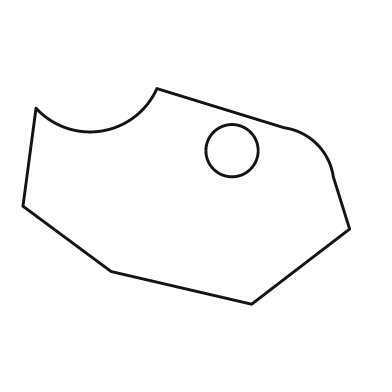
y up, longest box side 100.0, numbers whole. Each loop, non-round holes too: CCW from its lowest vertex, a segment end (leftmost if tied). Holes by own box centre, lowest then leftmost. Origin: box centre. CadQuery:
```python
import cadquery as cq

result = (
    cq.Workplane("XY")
    .moveTo(20.0, -33.0)
    .lineTo(50.0, -10.0)
    .lineTo(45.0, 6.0)
    .threePointArc((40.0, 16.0), (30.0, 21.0))
    .lineTo(-9.0, 33.0)
    .threePointArc((-26.0, 20.0), (-46.0, 27.0))
    .lineTo(-50.0, -3.0)
    .lineTo(-23.0, -23.0)
    .close()
    .moveTo(14.0, 14.0)
    .circle(8.0)
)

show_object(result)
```